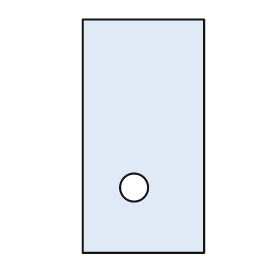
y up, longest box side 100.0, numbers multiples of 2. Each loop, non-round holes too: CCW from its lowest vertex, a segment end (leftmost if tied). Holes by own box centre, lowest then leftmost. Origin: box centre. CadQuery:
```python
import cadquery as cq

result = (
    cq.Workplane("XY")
    .moveTo(-26.0, -50.0)
    .lineTo(26.0, -50.0)
    .lineTo(26.0, 50.0)
    .lineTo(-26.0, 50.0)
    .close()
    .moveTo(-4.0, -22.0)
    .circle(6.0)
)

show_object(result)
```